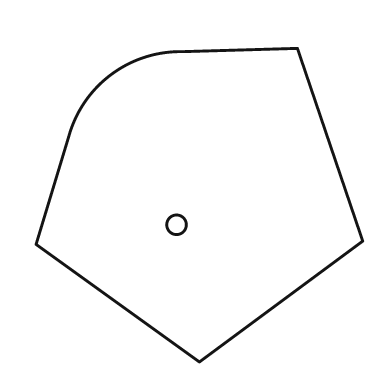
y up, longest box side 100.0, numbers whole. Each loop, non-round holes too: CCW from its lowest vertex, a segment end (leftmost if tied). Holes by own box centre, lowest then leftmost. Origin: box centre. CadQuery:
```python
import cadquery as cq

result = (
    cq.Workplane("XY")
    .moveTo(0.0, -48.0)
    .lineTo(50.0, -11.0)
    .lineTo(30.0, 48.0)
    .lineTo(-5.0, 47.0)
    .threePointArc((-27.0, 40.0), (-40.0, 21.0))
    .lineTo(-50.0, -12.0)
    .close()
    .moveTo(-7.0, -6.0)
    .circle(3.0)
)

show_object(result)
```